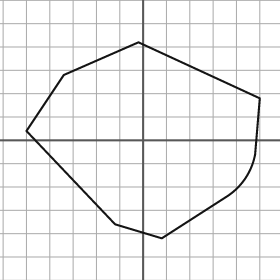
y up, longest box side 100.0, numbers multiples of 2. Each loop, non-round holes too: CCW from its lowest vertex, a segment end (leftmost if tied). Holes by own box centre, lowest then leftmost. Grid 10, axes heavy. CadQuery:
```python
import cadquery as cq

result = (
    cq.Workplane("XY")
    .moveTo(8.0, -42.0)
    .lineTo(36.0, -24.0)
    .threePointArc((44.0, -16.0), (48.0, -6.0))
    .lineTo(50.0, 18.0)
    .lineTo(-2.0, 42.0)
    .lineTo(-34.0, 28.0)
    .lineTo(-50.0, 4.0)
    .lineTo(-12.0, -36.0)
    .close()
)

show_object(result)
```